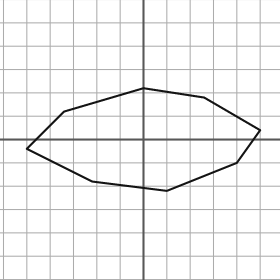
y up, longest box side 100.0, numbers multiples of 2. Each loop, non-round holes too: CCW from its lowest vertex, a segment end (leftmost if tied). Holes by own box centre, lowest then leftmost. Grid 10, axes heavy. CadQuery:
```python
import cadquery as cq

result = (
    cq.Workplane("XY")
    .moveTo(10.0, -22.0)
    .lineTo(40.0, -10.0)
    .lineTo(50.0, 4.0)
    .lineTo(26.0, 18.0)
    .lineTo(0.0, 22.0)
    .lineTo(-34.0, 12.0)
    .lineTo(-50.0, -4.0)
    .lineTo(-22.0, -18.0)
    .close()
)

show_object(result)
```